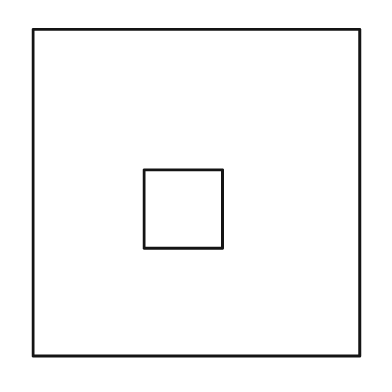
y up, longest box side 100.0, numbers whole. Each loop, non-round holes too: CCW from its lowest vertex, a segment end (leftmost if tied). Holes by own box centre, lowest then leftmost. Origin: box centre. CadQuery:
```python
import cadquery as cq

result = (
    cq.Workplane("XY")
    .moveTo(-50.0, -50.0)
    .lineTo(50.0, -50.0)
    .lineTo(50.0, 50.0)
    .lineTo(-50.0, 50.0)
    .close()
    .moveTo(-16.0, -17.0)
    .lineTo(8.0, -17.0)
    .lineTo(8.0, 7.0)
    .lineTo(-16.0, 7.0)
    .close()
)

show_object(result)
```